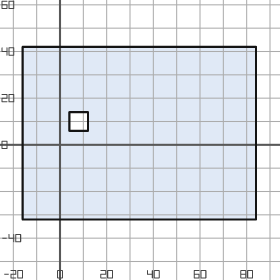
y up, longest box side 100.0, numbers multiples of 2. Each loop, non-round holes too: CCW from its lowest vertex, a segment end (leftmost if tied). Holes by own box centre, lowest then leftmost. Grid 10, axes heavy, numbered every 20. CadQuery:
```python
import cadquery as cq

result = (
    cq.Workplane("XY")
    .moveTo(-16.0, -32.0)
    .lineTo(84.0, -32.0)
    .lineTo(84.0, 42.0)
    .lineTo(-16.0, 42.0)
    .close()
    .moveTo(4.0, 6.0)
    .lineTo(12.0, 6.0)
    .lineTo(12.0, 14.0)
    .lineTo(4.0, 14.0)
    .close()
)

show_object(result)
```